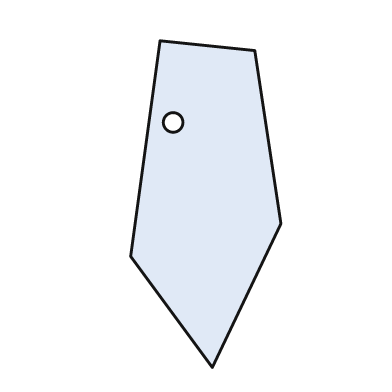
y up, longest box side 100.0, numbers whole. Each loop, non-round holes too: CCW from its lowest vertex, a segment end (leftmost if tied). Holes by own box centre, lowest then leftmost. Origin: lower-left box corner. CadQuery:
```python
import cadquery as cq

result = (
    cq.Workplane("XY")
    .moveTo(25.0, 0.0)
    .lineTo(46.0, 44.0)
    .lineTo(38.0, 97.0)
    .lineTo(9.0, 100.0)
    .lineTo(0.0, 34.0)
    .close()
    .moveTo(13.0, 75.0)
    .circle(3.0)
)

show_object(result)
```